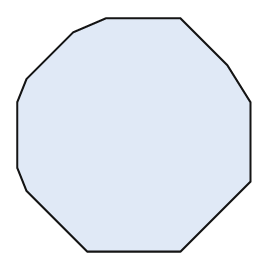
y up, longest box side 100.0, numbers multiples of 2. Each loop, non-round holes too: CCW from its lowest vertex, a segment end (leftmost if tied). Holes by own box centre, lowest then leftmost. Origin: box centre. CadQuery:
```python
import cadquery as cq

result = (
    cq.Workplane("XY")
    .moveTo(-20.0, -50.0)
    .lineTo(20.0, -50.0)
    .lineTo(50.0, -20.0)
    .lineTo(50.0, 14.0)
    .lineTo(40.0, 30.0)
    .lineTo(20.0, 50.0)
    .lineTo(-12.0, 50.0)
    .lineTo(-26.0, 44.0)
    .lineTo(-46.0, 24.0)
    .lineTo(-50.0, 14.0)
    .lineTo(-50.0, -14.0)
    .lineTo(-46.0, -24.0)
    .close()
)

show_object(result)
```